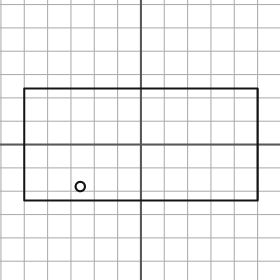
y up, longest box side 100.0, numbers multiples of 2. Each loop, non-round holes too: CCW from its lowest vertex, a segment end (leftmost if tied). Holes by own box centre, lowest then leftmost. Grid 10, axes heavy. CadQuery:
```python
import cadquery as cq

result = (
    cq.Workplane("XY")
    .moveTo(-50.0, -24.0)
    .lineTo(50.0, -24.0)
    .lineTo(50.0, 24.0)
    .lineTo(-50.0, 24.0)
    .close()
    .moveTo(-26.0, -18.0)
    .circle(2.0)
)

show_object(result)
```